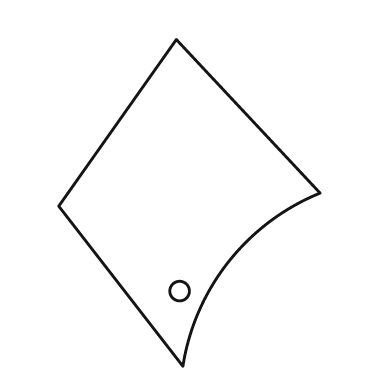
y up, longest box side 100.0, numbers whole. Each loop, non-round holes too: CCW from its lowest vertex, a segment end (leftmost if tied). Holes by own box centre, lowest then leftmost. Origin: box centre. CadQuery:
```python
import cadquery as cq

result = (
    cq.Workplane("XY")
    .moveTo(-2.0, -50.0)
    .threePointArc((12.0, -18.0), (40.0, 3.0))
    .lineTo(-4.0, 50.0)
    .lineTo(-40.0, -1.0)
    .close()
    .moveTo(-3.0, -27.0)
    .circle(3.0)
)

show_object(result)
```